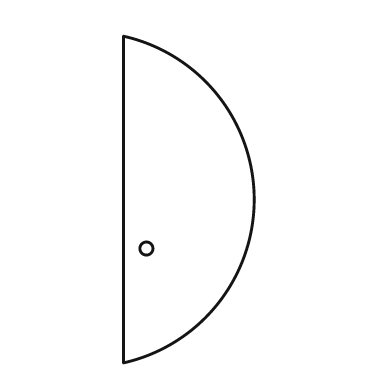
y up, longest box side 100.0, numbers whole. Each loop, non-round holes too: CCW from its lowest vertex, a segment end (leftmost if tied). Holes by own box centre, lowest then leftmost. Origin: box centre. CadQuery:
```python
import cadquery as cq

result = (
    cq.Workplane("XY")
    .moveTo(-20.0, -50.0)
    .threePointArc((20.0, 0.0), (-20.0, 50.0))
    .close()
    .moveTo(-13.0, -15.0)
    .circle(2.0)
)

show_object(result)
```